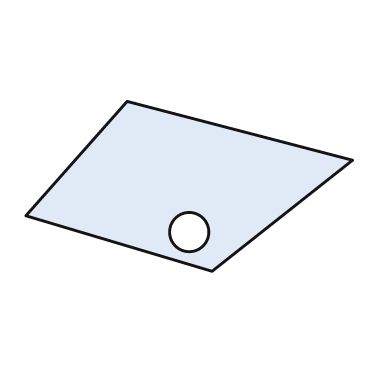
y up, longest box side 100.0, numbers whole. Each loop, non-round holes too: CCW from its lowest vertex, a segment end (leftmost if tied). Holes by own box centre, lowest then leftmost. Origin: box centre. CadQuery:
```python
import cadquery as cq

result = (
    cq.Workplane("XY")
    .moveTo(7.0, -26.0)
    .lineTo(50.0, 8.0)
    .lineTo(-19.0, 26.0)
    .lineTo(-50.0, -9.0)
    .close()
    .moveTo(0.0, -14.0)
    .circle(6.0)
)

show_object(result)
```